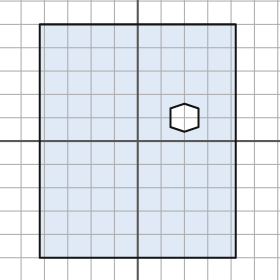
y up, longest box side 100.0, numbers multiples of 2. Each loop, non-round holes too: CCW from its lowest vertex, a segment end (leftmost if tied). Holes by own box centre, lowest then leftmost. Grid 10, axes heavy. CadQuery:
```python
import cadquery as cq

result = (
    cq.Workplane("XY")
    .moveTo(-42.0, -50.0)
    .lineTo(42.0, -50.0)
    .lineTo(42.0, 50.0)
    .lineTo(-42.0, 50.0)
    .close()
    .moveTo(20.0, 4.0)
    .lineTo(26.0, 6.0)
    .lineTo(26.0, 14.0)
    .lineTo(20.0, 16.0)
    .lineTo(14.0, 14.0)
    .lineTo(14.0, 6.0)
    .close()
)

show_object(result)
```